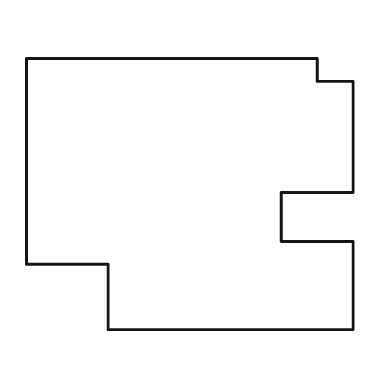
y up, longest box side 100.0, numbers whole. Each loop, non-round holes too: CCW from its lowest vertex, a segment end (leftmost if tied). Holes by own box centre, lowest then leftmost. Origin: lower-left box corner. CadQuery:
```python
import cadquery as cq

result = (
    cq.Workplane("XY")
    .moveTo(25.0, 0.0)
    .lineTo(100.0, 0.0)
    .lineTo(100.0, 27.0)
    .lineTo(78.0, 27.0)
    .lineTo(78.0, 42.0)
    .lineTo(100.0, 42.0)
    .lineTo(100.0, 76.0)
    .lineTo(89.0, 76.0)
    .lineTo(89.0, 83.0)
    .lineTo(0.0, 83.0)
    .lineTo(0.0, 20.0)
    .lineTo(25.0, 20.0)
    .close()
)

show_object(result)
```